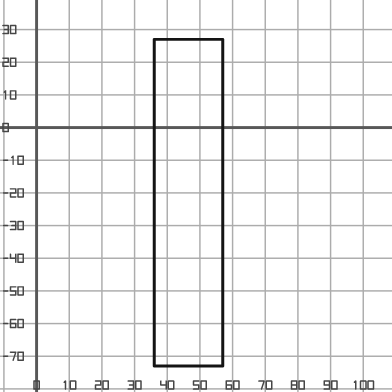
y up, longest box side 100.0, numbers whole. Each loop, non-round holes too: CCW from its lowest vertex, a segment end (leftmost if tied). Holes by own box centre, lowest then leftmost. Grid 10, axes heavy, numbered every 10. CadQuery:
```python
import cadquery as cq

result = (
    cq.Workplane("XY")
    .moveTo(36.0, -73.0)
    .lineTo(57.0, -73.0)
    .lineTo(57.0, 27.0)
    .lineTo(36.0, 27.0)
    .close()
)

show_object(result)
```